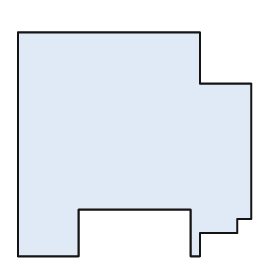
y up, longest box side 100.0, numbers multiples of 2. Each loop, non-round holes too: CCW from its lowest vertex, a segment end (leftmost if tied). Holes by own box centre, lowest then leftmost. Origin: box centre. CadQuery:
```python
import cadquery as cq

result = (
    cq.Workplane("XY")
    .moveTo(-50.0, -48.0)
    .lineTo(-24.0, -48.0)
    .lineTo(-24.0, -28.0)
    .lineTo(24.0, -28.0)
    .lineTo(24.0, -48.0)
    .lineTo(28.0, -48.0)
    .lineTo(28.0, -38.0)
    .lineTo(44.0, -38.0)
    .lineTo(44.0, -32.0)
    .lineTo(50.0, -32.0)
    .lineTo(50.0, 26.0)
    .lineTo(28.0, 26.0)
    .lineTo(28.0, 48.0)
    .lineTo(-50.0, 48.0)
    .close()
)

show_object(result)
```